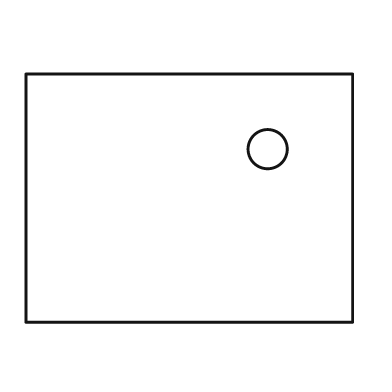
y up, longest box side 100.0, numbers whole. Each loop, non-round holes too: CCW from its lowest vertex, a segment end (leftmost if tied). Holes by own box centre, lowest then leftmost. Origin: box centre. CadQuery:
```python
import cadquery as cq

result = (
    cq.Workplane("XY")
    .moveTo(-50.0, -38.0)
    .lineTo(50.0, -38.0)
    .lineTo(50.0, 38.0)
    .lineTo(-50.0, 38.0)
    .close()
    .moveTo(24.0, 15.0)
    .circle(6.0)
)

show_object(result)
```